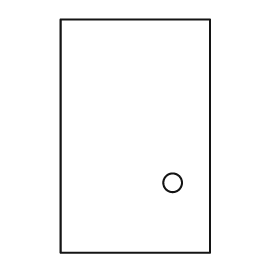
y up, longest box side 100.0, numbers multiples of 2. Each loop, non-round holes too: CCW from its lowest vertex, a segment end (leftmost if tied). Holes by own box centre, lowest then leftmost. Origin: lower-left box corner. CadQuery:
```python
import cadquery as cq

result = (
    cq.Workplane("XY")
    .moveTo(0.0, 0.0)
    .lineTo(64.0, 0.0)
    .lineTo(64.0, 100.0)
    .lineTo(0.0, 100.0)
    .close()
    .moveTo(48.0, 30.0)
    .circle(4.0)
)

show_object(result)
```